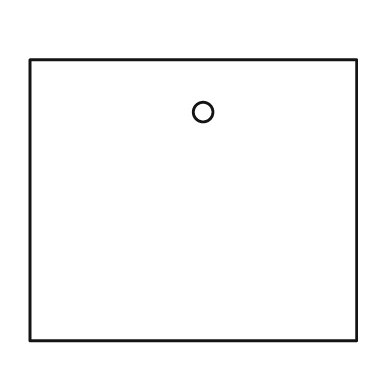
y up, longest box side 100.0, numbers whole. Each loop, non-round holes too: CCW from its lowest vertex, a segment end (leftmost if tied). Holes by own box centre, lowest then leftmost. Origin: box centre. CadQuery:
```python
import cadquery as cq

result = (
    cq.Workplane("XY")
    .moveTo(-50.0, -43.0)
    .lineTo(50.0, -43.0)
    .lineTo(50.0, 43.0)
    .lineTo(-50.0, 43.0)
    .close()
    .moveTo(3.0, 27.0)
    .circle(3.0)
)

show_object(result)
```